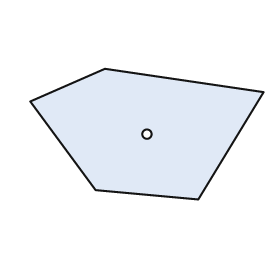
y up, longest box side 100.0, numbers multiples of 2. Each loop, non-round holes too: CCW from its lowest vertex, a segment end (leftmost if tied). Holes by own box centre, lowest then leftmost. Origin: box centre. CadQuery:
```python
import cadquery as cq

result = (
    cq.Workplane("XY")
    .moveTo(22.0, -28.0)
    .lineTo(50.0, 18.0)
    .lineTo(-18.0, 28.0)
    .lineTo(-50.0, 14.0)
    .lineTo(-22.0, -24.0)
    .close()
    .moveTo(0.0, 0.0)
    .circle(2.0)
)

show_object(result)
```